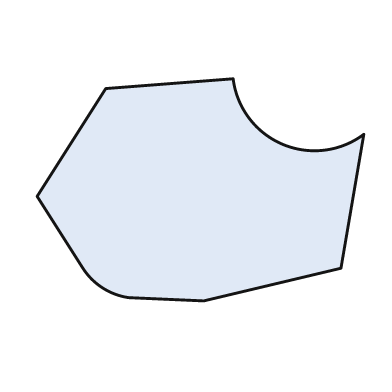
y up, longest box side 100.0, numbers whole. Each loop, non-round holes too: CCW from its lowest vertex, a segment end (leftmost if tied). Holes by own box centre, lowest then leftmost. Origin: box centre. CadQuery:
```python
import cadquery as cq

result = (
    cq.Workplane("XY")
    .moveTo(1.0, -34.0)
    .lineTo(43.0, -24.0)
    .lineTo(50.0, 17.0)
    .threePointArc((25.0, 14.0), (10.0, 34.0))
    .lineTo(-29.0, 31.0)
    .lineTo(-50.0, -2.0)
    .lineTo(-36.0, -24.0)
    .threePointArc((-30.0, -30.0), (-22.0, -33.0))
    .close()
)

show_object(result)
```